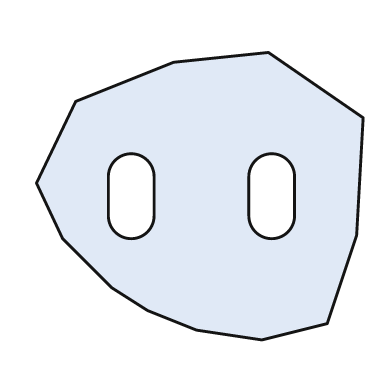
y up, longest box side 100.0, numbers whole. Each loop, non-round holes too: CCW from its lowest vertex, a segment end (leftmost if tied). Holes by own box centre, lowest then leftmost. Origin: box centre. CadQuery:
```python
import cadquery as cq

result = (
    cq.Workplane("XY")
    .moveTo(19.0, -44.0)
    .lineTo(39.0, -39.0)
    .lineTo(48.0, -12.0)
    .lineTo(50.0, 24.0)
    .lineTo(21.0, 44.0)
    .lineTo(-8.0, 41.0)
    .lineTo(-38.0, 29.0)
    .lineTo(-50.0, 4.0)
    .lineTo(-42.0, -13.0)
    .lineTo(-27.0, -28.0)
    .lineTo(-16.0, -35.0)
    .lineTo(-1.0, -41.0)
    .close()
    .moveTo(-28.0, -6.0)
    .threePointArc((-21.0, -13.0), (-14.0, -6.0))
    .lineTo(-14.0, 6.0)
    .threePointArc((-21.0, 13.0), (-28.0, 6.0))
    .close()
    .moveTo(15.0, -6.0)
    .threePointArc((22.0, -13.0), (29.0, -6.0))
    .lineTo(29.0, 6.0)
    .threePointArc((22.0, 13.0), (15.0, 6.0))
    .close()
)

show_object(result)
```